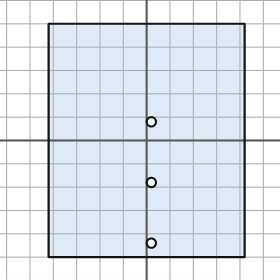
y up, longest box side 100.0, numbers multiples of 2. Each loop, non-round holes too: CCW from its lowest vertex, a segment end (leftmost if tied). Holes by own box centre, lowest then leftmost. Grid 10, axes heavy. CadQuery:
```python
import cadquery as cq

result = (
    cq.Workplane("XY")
    .moveTo(-42.0, -50.0)
    .lineTo(42.0, -50.0)
    .lineTo(42.0, 50.0)
    .lineTo(-42.0, 50.0)
    .close()
    .moveTo(2.0, -44.0)
    .circle(2.0)
    .moveTo(2.0, -18.0)
    .circle(2.0)
    .moveTo(2.0, 8.0)
    .circle(2.0)
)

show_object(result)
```